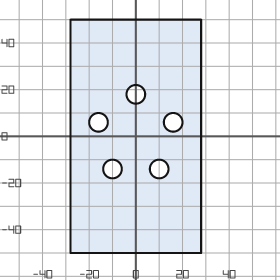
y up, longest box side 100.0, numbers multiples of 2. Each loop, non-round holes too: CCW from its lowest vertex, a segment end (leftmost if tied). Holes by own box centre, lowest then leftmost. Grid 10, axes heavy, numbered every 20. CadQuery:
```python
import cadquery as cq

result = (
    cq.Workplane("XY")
    .moveTo(-28.0, -50.0)
    .lineTo(28.0, -50.0)
    .lineTo(28.0, 50.0)
    .lineTo(-28.0, 50.0)
    .close()
    .moveTo(-10.0, -14.0)
    .circle(4.0)
    .moveTo(10.0, -14.0)
    .circle(4.0)
    .moveTo(-16.0, 6.0)
    .circle(4.0)
    .moveTo(16.0, 6.0)
    .circle(4.0)
    .moveTo(0.0, 18.0)
    .circle(4.0)
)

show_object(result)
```